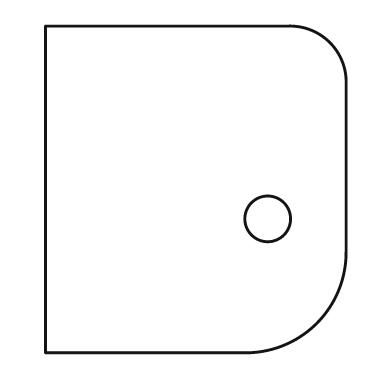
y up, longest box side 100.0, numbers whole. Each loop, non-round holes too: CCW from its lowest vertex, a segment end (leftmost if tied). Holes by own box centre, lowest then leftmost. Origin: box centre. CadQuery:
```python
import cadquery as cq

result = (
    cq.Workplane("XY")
    .moveTo(-46.0, -50.0)
    .lineTo(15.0, -50.0)
    .threePointArc((37.0, -41.0), (46.0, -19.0))
    .lineTo(46.0, 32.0)
    .threePointArc((41.0, 45.0), (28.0, 50.0))
    .lineTo(-46.0, 50.0)
    .close()
    .moveTo(22.0, -9.0)
    .circle(7.0)
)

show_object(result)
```